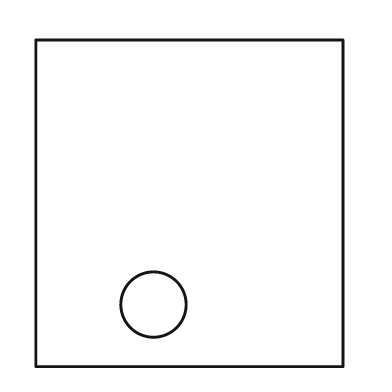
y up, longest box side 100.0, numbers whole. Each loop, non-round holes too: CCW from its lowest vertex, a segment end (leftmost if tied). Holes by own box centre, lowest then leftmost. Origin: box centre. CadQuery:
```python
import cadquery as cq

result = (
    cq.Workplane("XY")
    .moveTo(-47.0, -50.0)
    .lineTo(47.0, -50.0)
    .lineTo(47.0, 50.0)
    .lineTo(-47.0, 50.0)
    .close()
    .moveTo(-11.0, -31.0)
    .circle(10.0)
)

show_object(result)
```